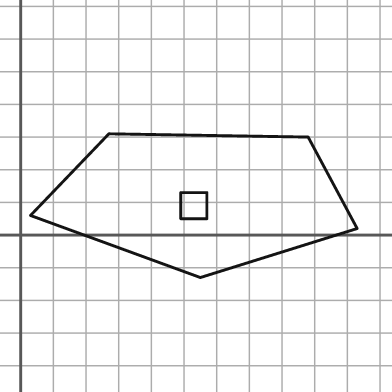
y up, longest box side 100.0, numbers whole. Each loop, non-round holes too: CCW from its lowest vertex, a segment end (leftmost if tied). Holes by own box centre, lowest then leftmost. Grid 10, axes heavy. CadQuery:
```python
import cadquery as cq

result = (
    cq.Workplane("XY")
    .moveTo(55.0, -13.0)
    .lineTo(103.0, 2.0)
    .lineTo(88.0, 30.0)
    .lineTo(27.0, 31.0)
    .lineTo(3.0, 6.0)
    .close()
    .moveTo(49.0, 5.0)
    .lineTo(57.0, 5.0)
    .lineTo(57.0, 13.0)
    .lineTo(49.0, 13.0)
    .close()
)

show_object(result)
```